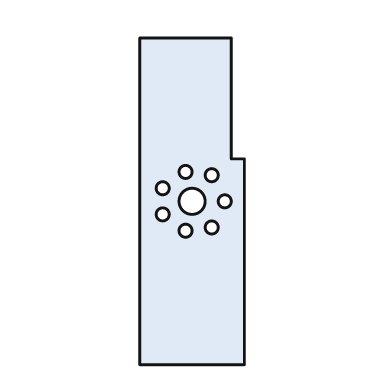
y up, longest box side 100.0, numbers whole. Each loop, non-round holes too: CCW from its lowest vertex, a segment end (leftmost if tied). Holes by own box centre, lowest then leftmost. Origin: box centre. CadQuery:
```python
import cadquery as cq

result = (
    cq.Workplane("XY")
    .moveTo(-16.0, -50.0)
    .lineTo(16.0, -50.0)
    .lineTo(16.0, 13.0)
    .lineTo(12.0, 13.0)
    .lineTo(12.0, 50.0)
    .lineTo(-16.0, 50.0)
    .close()
    .moveTo(-2.0, -9.0)
    .circle(2.0)
    .moveTo(6.0, -8.0)
    .circle(2.0)
    .moveTo(-9.0, -4.0)
    .circle(2.0)
    .moveTo(0.0, 0.0)
    .circle(4.0)
    .moveTo(10.0, 0.0)
    .circle(2.0)
    .moveTo(-9.0, 4.0)
    .circle(2.0)
    .moveTo(6.0, 8.0)
    .circle(2.0)
    .moveTo(-2.0, 9.0)
    .circle(2.0)
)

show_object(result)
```